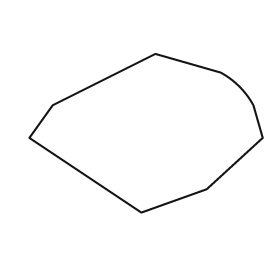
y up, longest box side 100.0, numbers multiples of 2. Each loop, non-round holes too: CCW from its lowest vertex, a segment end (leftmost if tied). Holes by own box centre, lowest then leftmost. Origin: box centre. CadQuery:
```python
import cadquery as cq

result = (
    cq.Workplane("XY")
    .moveTo(-2.0, -34.0)
    .lineTo(26.0, -24.0)
    .lineTo(50.0, -2.0)
    .lineTo(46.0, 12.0)
    .threePointArc((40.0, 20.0), (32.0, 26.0))
    .lineTo(4.0, 34.0)
    .lineTo(-40.0, 12.0)
    .lineTo(-50.0, -2.0)
    .close()
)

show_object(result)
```